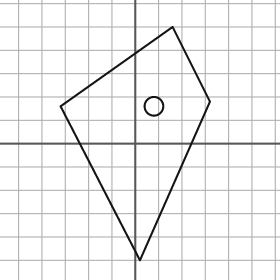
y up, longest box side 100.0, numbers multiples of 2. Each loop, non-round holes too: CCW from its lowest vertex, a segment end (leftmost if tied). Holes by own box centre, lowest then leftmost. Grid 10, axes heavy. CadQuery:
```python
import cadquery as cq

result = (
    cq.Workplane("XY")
    .moveTo(2.0, -50.0)
    .lineTo(32.0, 18.0)
    .lineTo(16.0, 50.0)
    .lineTo(-32.0, 16.0)
    .close()
    .moveTo(8.0, 16.0)
    .circle(4.0)
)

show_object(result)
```